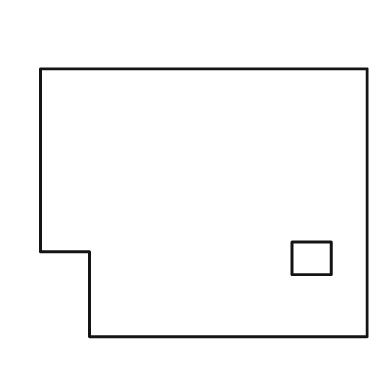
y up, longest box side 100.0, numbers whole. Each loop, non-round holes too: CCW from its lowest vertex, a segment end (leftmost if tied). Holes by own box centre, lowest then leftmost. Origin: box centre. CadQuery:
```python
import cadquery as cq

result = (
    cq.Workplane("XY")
    .moveTo(-35.0, -41.0)
    .lineTo(50.0, -41.0)
    .lineTo(50.0, 41.0)
    .lineTo(-50.0, 41.0)
    .lineTo(-50.0, -15.0)
    .lineTo(-35.0, -15.0)
    .close()
    .moveTo(27.0, -22.0)
    .lineTo(39.0, -22.0)
    .lineTo(39.0, -12.0)
    .lineTo(27.0, -12.0)
    .close()
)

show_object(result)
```